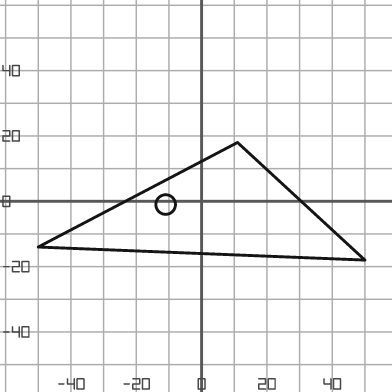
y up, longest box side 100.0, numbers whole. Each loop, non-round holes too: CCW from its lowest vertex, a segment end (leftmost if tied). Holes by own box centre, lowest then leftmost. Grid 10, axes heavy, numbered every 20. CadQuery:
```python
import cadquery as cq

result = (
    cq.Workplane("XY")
    .moveTo(50.0, -18.0)
    .lineTo(11.0, 18.0)
    .lineTo(-50.0, -14.0)
    .close()
    .moveTo(-11.0, -1.0)
    .circle(3.0)
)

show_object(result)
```